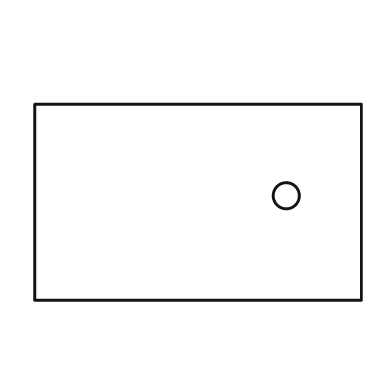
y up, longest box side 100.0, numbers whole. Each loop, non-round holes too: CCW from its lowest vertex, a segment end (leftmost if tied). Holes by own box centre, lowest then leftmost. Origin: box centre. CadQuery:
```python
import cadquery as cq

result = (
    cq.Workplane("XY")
    .moveTo(-50.0, -30.0)
    .lineTo(50.0, -30.0)
    .lineTo(50.0, 30.0)
    .lineTo(-50.0, 30.0)
    .close()
    .moveTo(27.0, 2.0)
    .circle(4.0)
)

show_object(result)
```